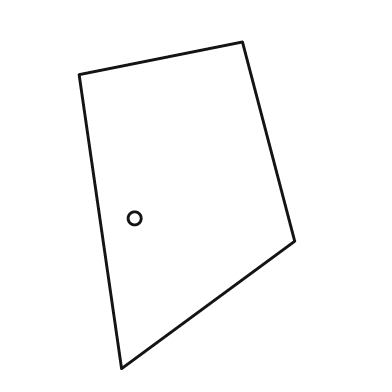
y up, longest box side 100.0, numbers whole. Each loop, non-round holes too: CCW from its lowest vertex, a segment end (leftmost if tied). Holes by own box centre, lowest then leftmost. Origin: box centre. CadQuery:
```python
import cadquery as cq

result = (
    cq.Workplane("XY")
    .moveTo(-20.0, -50.0)
    .lineTo(33.0, -11.0)
    .lineTo(17.0, 50.0)
    .lineTo(-33.0, 40.0)
    .close()
    .moveTo(-16.0, -4.0)
    .circle(2.0)
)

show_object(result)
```